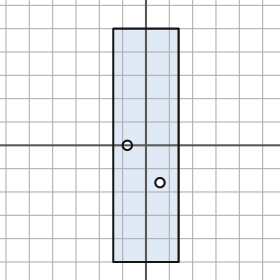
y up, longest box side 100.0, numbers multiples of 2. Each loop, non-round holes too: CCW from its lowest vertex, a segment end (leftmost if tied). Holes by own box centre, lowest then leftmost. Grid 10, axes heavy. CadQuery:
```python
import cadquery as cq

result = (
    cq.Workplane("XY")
    .moveTo(-14.0, -50.0)
    .lineTo(14.0, -50.0)
    .lineTo(14.0, 50.0)
    .lineTo(-14.0, 50.0)
    .close()
    .moveTo(6.0, -16.0)
    .circle(2.0)
    .moveTo(-8.0, 0.0)
    .circle(2.0)
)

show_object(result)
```